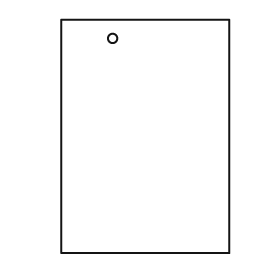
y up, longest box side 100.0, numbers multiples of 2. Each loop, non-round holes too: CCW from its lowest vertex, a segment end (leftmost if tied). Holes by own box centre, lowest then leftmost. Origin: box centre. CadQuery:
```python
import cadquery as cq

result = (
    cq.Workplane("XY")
    .moveTo(-36.0, -50.0)
    .lineTo(36.0, -50.0)
    .lineTo(36.0, 50.0)
    .lineTo(-36.0, 50.0)
    .close()
    .moveTo(-14.0, 42.0)
    .circle(2.0)
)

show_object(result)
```